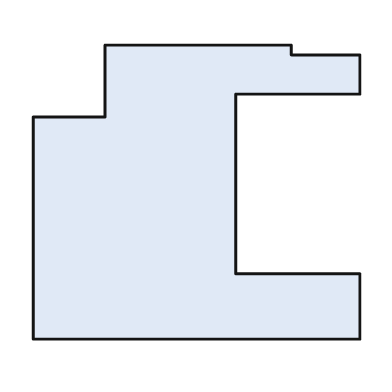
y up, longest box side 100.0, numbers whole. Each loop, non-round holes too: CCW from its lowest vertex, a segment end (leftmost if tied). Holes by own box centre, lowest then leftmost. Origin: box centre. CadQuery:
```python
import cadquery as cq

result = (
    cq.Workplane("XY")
    .moveTo(-50.0, -45.0)
    .lineTo(50.0, -45.0)
    .lineTo(50.0, -25.0)
    .lineTo(12.0, -25.0)
    .lineTo(12.0, 30.0)
    .lineTo(50.0, 30.0)
    .lineTo(50.0, 42.0)
    .lineTo(29.0, 42.0)
    .lineTo(29.0, 45.0)
    .lineTo(-28.0, 45.0)
    .lineTo(-28.0, 23.0)
    .lineTo(-50.0, 23.0)
    .close()
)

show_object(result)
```